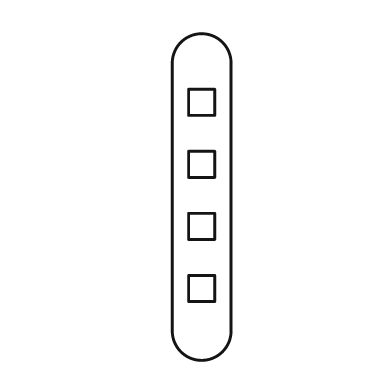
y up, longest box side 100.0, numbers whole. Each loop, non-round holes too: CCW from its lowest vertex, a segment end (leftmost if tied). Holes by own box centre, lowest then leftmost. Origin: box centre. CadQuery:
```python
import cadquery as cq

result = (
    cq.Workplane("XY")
    .moveTo(-9.0, -41.0)
    .threePointArc((0.0, -50.0), (9.0, -41.0))
    .lineTo(9.0, 41.0)
    .threePointArc((0.0, 50.0), (-9.0, 41.0))
    .close()
    .moveTo(-4.0, -32.0)
    .lineTo(4.0, -32.0)
    .lineTo(4.0, -24.0)
    .lineTo(-4.0, -24.0)
    .close()
    .moveTo(-4.0, -13.0)
    .lineTo(4.0, -13.0)
    .lineTo(4.0, -5.0)
    .lineTo(-4.0, -5.0)
    .close()
    .moveTo(-4.0, 6.0)
    .lineTo(4.0, 6.0)
    .lineTo(4.0, 14.0)
    .lineTo(-4.0, 14.0)
    .close()
    .moveTo(-4.0, 25.0)
    .lineTo(4.0, 25.0)
    .lineTo(4.0, 33.0)
    .lineTo(-4.0, 33.0)
    .close()
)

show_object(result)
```